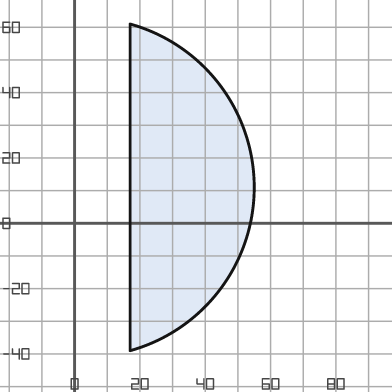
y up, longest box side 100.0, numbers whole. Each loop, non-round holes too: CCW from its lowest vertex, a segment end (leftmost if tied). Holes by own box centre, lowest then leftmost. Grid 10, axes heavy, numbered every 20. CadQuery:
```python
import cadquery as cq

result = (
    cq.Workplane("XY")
    .moveTo(17.0, -39.0)
    .threePointArc((55.0, 11.0), (17.0, 61.0))
    .close()
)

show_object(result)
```